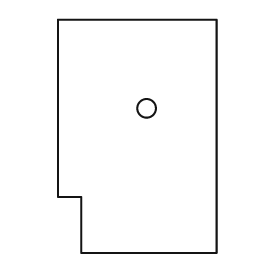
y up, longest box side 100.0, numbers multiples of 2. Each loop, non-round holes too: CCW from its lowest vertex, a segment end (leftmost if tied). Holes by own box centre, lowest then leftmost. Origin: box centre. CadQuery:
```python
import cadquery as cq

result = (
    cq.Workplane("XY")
    .moveTo(-24.0, -50.0)
    .lineTo(34.0, -50.0)
    .lineTo(34.0, 50.0)
    .lineTo(-34.0, 50.0)
    .lineTo(-34.0, -26.0)
    .lineTo(-24.0, -26.0)
    .close()
    .moveTo(4.0, 12.0)
    .circle(4.0)
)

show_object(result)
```